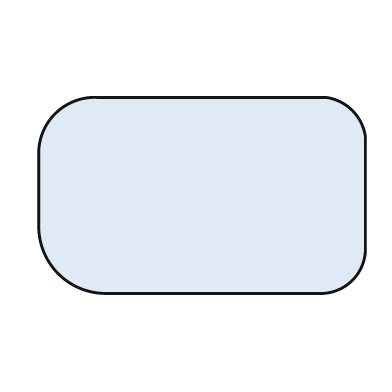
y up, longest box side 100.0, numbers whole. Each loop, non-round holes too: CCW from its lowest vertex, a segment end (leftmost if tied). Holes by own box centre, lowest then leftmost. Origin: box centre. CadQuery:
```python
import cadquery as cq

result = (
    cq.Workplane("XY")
    .moveTo(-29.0, -30.0)
    .lineTo(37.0, -30.0)
    .threePointArc((46.0, -26.0), (50.0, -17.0))
    .lineTo(50.0, 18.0)
    .threePointArc((46.0, 26.0), (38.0, 30.0))
    .lineTo(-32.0, 30.0)
    .threePointArc((-45.0, 25.0), (-50.0, 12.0))
    .lineTo(-50.0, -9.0)
    .threePointArc((-44.0, -24.0), (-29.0, -30.0))
    .close()
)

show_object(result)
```